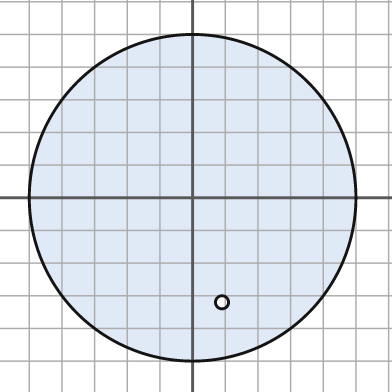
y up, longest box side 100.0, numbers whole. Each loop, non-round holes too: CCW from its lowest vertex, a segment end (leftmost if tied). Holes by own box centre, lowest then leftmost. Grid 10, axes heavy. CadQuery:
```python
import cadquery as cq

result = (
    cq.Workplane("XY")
    .moveTo(0.0, 0.0)
    .circle(50.0)
    .moveTo(9.0, -32.0)
    .circle(2.0)
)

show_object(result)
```